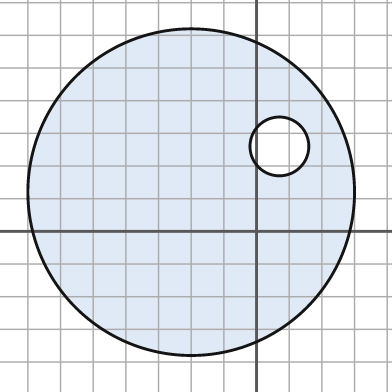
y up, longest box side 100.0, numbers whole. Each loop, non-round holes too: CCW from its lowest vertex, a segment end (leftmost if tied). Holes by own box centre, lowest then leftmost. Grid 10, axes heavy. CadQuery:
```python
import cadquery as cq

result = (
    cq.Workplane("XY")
    .moveTo(-20.0, 12.0)
    .circle(50.0)
    .moveTo(7.0, 26.0)
    .circle(9.0)
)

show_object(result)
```